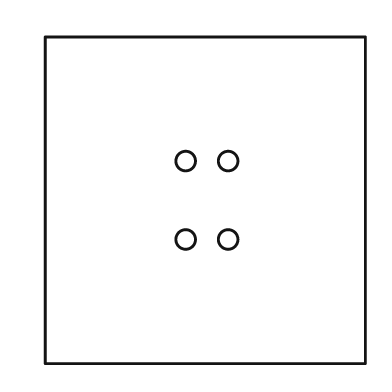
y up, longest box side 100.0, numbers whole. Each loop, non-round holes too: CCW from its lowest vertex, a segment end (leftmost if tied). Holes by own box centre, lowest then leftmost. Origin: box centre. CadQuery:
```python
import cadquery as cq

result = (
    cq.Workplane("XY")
    .moveTo(-49.0, -50.0)
    .lineTo(49.0, -50.0)
    .lineTo(49.0, 50.0)
    .lineTo(-49.0, 50.0)
    .close()
    .moveTo(-6.0, -12.0)
    .circle(3.0)
    .moveTo(7.0, -12.0)
    .circle(3.0)
    .moveTo(-6.0, 12.0)
    .circle(3.0)
    .moveTo(7.0, 12.0)
    .circle(3.0)
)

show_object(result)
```